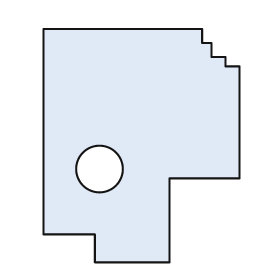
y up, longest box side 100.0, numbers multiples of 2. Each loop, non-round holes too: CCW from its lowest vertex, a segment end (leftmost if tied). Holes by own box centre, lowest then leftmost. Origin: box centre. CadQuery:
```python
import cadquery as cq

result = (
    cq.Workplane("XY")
    .moveTo(-20.0, -50.0)
    .lineTo(12.0, -50.0)
    .lineTo(12.0, -14.0)
    .lineTo(42.0, -14.0)
    .lineTo(42.0, 34.0)
    .lineTo(36.0, 34.0)
    .lineTo(36.0, 38.0)
    .lineTo(30.0, 38.0)
    .lineTo(30.0, 44.0)
    .lineTo(26.0, 44.0)
    .lineTo(26.0, 50.0)
    .lineTo(-42.0, 50.0)
    .lineTo(-42.0, -38.0)
    .lineTo(-20.0, -38.0)
    .close()
    .moveTo(-18.0, -10.0)
    .circle(10.0)
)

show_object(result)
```